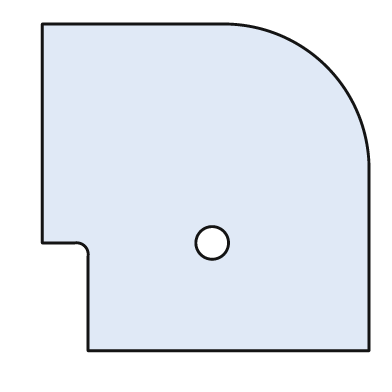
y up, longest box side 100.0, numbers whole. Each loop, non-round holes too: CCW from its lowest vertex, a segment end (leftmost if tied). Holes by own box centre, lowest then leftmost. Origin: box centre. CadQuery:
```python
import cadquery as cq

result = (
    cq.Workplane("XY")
    .moveTo(-36.0, -50.0)
    .lineTo(50.0, -50.0)
    .lineTo(50.0, 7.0)
    .threePointArc((37.0, 37.0), (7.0, 50.0))
    .lineTo(-50.0, 50.0)
    .lineTo(-50.0, -17.0)
    .lineTo(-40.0, -17.0)
    .threePointArc((-37.0, -18.0), (-36.0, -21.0))
    .close()
    .moveTo(2.0, -17.0)
    .circle(5.0)
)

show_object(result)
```